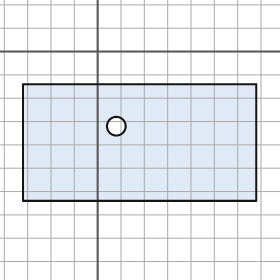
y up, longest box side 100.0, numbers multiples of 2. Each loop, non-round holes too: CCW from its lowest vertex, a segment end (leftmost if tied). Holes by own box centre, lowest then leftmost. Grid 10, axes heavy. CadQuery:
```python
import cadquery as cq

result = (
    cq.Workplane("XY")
    .moveTo(-32.0, -64.0)
    .lineTo(68.0, -64.0)
    .lineTo(68.0, -14.0)
    .lineTo(-32.0, -14.0)
    .close()
    .moveTo(8.0, -32.0)
    .circle(4.0)
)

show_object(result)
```